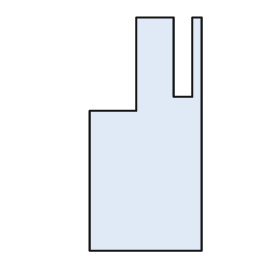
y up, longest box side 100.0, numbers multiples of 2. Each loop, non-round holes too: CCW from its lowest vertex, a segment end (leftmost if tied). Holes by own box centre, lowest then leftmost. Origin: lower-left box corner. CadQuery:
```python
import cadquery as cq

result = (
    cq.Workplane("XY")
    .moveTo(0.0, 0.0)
    .lineTo(48.0, 0.0)
    .lineTo(48.0, 100.0)
    .lineTo(44.0, 100.0)
    .lineTo(44.0, 66.0)
    .lineTo(36.0, 66.0)
    .lineTo(36.0, 100.0)
    .lineTo(20.0, 100.0)
    .lineTo(20.0, 60.0)
    .lineTo(0.0, 60.0)
    .close()
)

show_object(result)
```